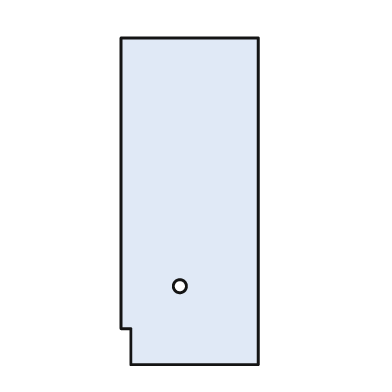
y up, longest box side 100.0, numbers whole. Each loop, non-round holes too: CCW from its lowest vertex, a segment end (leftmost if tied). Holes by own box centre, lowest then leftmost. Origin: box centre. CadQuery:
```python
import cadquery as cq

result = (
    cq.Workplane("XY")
    .moveTo(-18.0, -50.0)
    .lineTo(21.0, -50.0)
    .lineTo(21.0, 50.0)
    .lineTo(-21.0, 50.0)
    .lineTo(-21.0, -39.0)
    .lineTo(-18.0, -39.0)
    .close()
    .moveTo(-3.0, -26.0)
    .circle(2.0)
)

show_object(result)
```